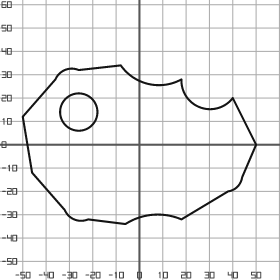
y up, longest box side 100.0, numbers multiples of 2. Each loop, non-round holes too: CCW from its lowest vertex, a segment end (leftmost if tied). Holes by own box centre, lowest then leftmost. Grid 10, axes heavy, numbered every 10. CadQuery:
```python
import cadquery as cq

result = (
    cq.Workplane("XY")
    .moveTo(-6.0, -34.0)
    .threePointArc((6.0, -30.0), (18.0, -32.0))
    .lineTo(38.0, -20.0)
    .threePointArc((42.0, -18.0), (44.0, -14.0))
    .lineTo(50.0, 0.0)
    .lineTo(40.0, 20.0)
    .threePointArc((26.0, 16.0), (18.0, 28.0))
    .threePointArc((4.0, 26.0), (-8.0, 34.0))
    .lineTo(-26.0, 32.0)
    .threePointArc((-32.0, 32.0), (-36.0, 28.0))
    .lineTo(-50.0, 12.0)
    .lineTo(-46.0, -12.0)
    .lineTo(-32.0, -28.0)
    .threePointArc((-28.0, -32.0), (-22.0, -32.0))
    .close()
    .moveTo(-26.0, 14.0)
    .circle(8.0)
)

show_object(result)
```